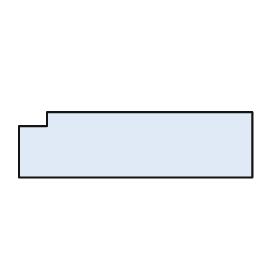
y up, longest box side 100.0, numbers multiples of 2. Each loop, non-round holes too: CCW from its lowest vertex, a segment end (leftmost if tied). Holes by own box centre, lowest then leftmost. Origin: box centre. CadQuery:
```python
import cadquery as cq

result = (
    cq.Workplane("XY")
    .moveTo(-50.0, -14.0)
    .lineTo(50.0, -14.0)
    .lineTo(50.0, 14.0)
    .lineTo(-38.0, 14.0)
    .lineTo(-38.0, 8.0)
    .lineTo(-50.0, 8.0)
    .close()
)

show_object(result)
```